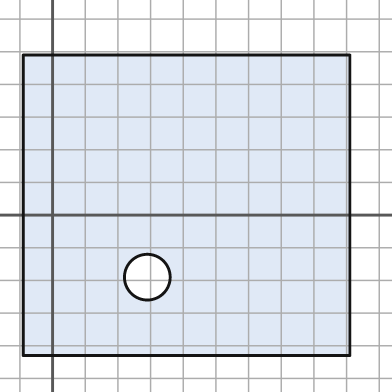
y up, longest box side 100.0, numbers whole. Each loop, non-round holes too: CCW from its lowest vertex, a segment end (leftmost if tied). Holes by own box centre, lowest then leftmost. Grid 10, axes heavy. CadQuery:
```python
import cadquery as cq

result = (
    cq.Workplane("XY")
    .moveTo(-9.0, -43.0)
    .lineTo(91.0, -43.0)
    .lineTo(91.0, 49.0)
    .lineTo(-9.0, 49.0)
    .close()
    .moveTo(29.0, -19.0)
    .circle(7.0)
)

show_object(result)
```